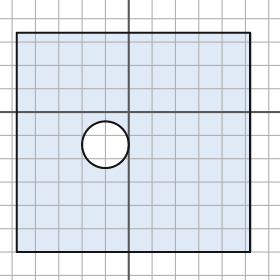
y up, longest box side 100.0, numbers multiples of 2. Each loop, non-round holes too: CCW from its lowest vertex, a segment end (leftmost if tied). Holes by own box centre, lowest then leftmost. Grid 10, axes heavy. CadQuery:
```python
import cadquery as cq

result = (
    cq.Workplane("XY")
    .moveTo(-48.0, -60.0)
    .lineTo(52.0, -60.0)
    .lineTo(52.0, 34.0)
    .lineTo(-48.0, 34.0)
    .close()
    .moveTo(-10.0, -14.0)
    .circle(10.0)
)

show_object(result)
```